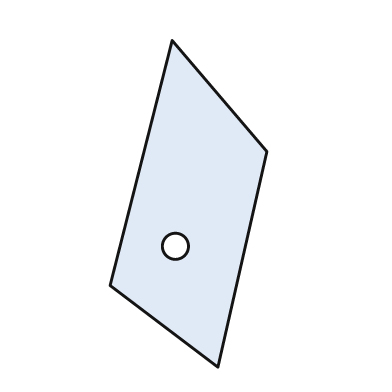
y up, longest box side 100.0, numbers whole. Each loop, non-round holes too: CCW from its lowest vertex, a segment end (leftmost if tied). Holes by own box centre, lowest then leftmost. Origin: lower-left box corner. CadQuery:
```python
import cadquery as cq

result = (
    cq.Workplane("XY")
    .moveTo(33.0, 0.0)
    .lineTo(48.0, 66.0)
    .lineTo(19.0, 100.0)
    .lineTo(0.0, 25.0)
    .close()
    .moveTo(20.0, 37.0)
    .circle(4.0)
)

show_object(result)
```